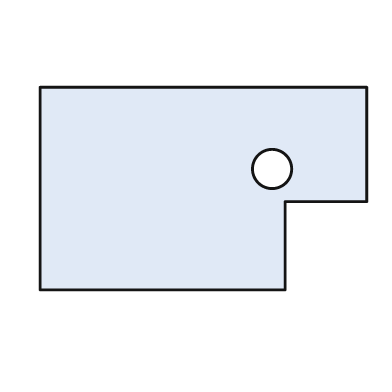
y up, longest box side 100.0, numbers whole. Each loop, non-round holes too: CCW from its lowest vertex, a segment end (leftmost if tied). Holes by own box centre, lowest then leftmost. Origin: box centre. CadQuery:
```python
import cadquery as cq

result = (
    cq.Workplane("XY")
    .moveTo(-50.0, -31.0)
    .lineTo(25.0, -31.0)
    .lineTo(25.0, -4.0)
    .lineTo(50.0, -4.0)
    .lineTo(50.0, 31.0)
    .lineTo(-50.0, 31.0)
    .close()
    .moveTo(21.0, 6.0)
    .circle(6.0)
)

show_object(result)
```